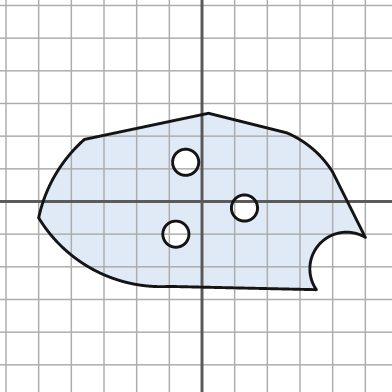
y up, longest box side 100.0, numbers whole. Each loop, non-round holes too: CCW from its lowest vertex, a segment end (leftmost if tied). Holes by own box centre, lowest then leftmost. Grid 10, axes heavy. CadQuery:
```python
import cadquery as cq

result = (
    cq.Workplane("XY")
    .moveTo(35.0, -27.0)
    .threePointArc((36.0, -13.0), (50.0, -11.0))
    .lineTo(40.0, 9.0)
    .threePointArc((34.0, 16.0), (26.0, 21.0))
    .lineTo(2.0, 27.0)
    .lineTo(-36.0, 19.0)
    .threePointArc((-45.0, 8.0), (-50.0, -5.0))
    .threePointArc((-33.0, -21.0), (-10.0, -26.0))
    .close()
    .moveTo(-8.0, -10.0)
    .circle(4.0)
    .moveTo(13.0, -2.0)
    .circle(4.0)
    .moveTo(-5.0, 12.0)
    .circle(4.0)
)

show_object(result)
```